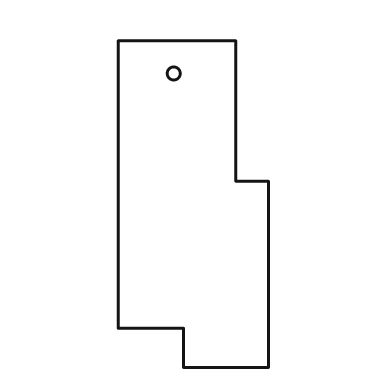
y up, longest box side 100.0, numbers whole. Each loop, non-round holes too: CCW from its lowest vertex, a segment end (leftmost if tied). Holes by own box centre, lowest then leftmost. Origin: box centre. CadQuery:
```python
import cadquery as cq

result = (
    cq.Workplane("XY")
    .moveTo(-3.0, -50.0)
    .lineTo(23.0, -50.0)
    .lineTo(23.0, 7.0)
    .lineTo(13.0, 7.0)
    .lineTo(13.0, 50.0)
    .lineTo(-23.0, 50.0)
    .lineTo(-23.0, -38.0)
    .lineTo(-3.0, -38.0)
    .close()
    .moveTo(-6.0, 40.0)
    .circle(2.0)
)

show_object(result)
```